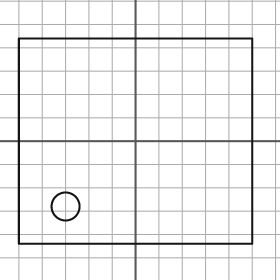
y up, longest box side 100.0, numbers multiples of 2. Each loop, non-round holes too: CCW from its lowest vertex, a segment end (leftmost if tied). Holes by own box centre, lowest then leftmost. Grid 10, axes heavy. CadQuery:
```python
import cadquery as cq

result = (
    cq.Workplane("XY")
    .moveTo(-50.0, -44.0)
    .lineTo(50.0, -44.0)
    .lineTo(50.0, 44.0)
    .lineTo(-50.0, 44.0)
    .close()
    .moveTo(-30.0, -28.0)
    .circle(6.0)
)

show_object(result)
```